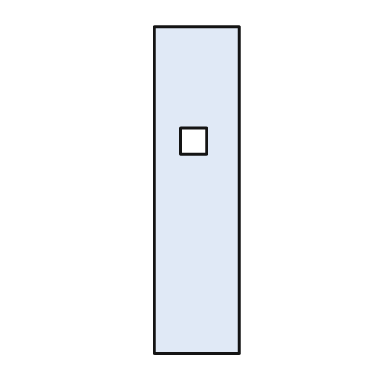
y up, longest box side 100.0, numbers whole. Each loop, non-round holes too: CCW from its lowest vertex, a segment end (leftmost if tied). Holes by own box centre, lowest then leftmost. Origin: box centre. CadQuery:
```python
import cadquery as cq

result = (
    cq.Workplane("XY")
    .moveTo(-13.0, -50.0)
    .lineTo(13.0, -50.0)
    .lineTo(13.0, 50.0)
    .lineTo(-13.0, 50.0)
    .close()
    .moveTo(-5.0, 11.0)
    .lineTo(3.0, 11.0)
    .lineTo(3.0, 19.0)
    .lineTo(-5.0, 19.0)
    .close()
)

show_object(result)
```